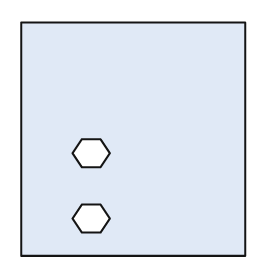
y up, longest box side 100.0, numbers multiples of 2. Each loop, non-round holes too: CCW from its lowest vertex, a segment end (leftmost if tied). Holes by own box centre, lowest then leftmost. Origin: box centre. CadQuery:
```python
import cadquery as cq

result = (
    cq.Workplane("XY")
    .moveTo(-48.0, -50.0)
    .lineTo(48.0, -50.0)
    .lineTo(48.0, 50.0)
    .lineTo(-48.0, 50.0)
    .close()
    .moveTo(-22.0, -40.0)
    .lineTo(-14.0, -40.0)
    .lineTo(-10.0, -34.0)
    .lineTo(-14.0, -28.0)
    .lineTo(-22.0, -28.0)
    .lineTo(-26.0, -34.0)
    .close()
    .moveTo(-22.0, -12.0)
    .lineTo(-14.0, -12.0)
    .lineTo(-10.0, -6.0)
    .lineTo(-14.0, 0.0)
    .lineTo(-22.0, 0.0)
    .lineTo(-26.0, -6.0)
    .close()
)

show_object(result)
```